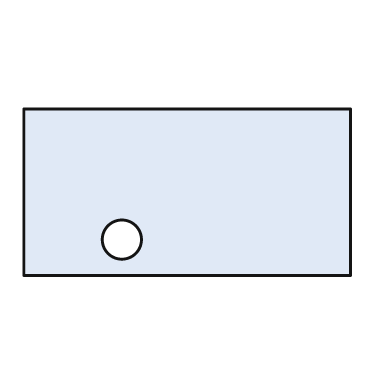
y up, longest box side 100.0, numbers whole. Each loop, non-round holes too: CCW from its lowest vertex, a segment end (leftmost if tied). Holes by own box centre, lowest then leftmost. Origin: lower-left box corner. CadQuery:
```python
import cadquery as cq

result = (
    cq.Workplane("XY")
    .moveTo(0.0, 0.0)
    .lineTo(100.0, 0.0)
    .lineTo(100.0, 51.0)
    .lineTo(0.0, 51.0)
    .close()
    .moveTo(30.0, 11.0)
    .circle(6.0)
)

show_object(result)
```